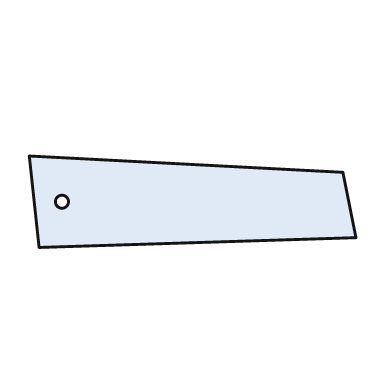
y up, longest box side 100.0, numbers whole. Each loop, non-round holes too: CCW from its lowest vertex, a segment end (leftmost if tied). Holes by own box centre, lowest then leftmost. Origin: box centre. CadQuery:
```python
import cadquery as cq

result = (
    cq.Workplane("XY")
    .moveTo(-47.0, -14.0)
    .lineTo(50.0, -11.0)
    .lineTo(46.0, 9.0)
    .lineTo(-50.0, 14.0)
    .close()
    .moveTo(-40.0, 0.0)
    .circle(2.0)
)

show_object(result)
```